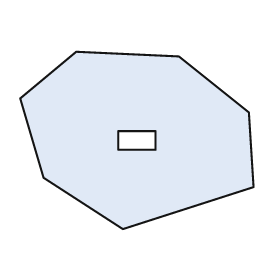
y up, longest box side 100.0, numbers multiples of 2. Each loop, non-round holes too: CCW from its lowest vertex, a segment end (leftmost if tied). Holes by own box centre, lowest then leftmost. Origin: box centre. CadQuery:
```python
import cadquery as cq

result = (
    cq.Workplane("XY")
    .moveTo(-6.0, -38.0)
    .lineTo(50.0, -20.0)
    .lineTo(48.0, 12.0)
    .lineTo(18.0, 36.0)
    .lineTo(-26.0, 38.0)
    .lineTo(-50.0, 18.0)
    .lineTo(-40.0, -16.0)
    .close()
    .moveTo(-8.0, -4.0)
    .lineTo(8.0, -4.0)
    .lineTo(8.0, 4.0)
    .lineTo(-8.0, 4.0)
    .close()
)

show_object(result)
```